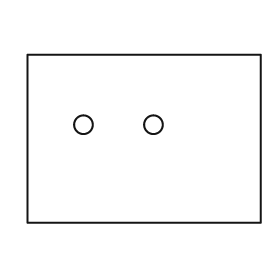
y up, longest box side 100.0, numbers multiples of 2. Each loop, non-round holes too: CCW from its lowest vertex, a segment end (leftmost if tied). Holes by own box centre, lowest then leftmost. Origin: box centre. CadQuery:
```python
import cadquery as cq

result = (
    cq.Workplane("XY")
    .moveTo(-50.0, -36.0)
    .lineTo(50.0, -36.0)
    .lineTo(50.0, 36.0)
    .lineTo(-50.0, 36.0)
    .close()
    .moveTo(-26.0, 6.0)
    .circle(4.0)
    .moveTo(4.0, 6.0)
    .circle(4.0)
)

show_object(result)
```